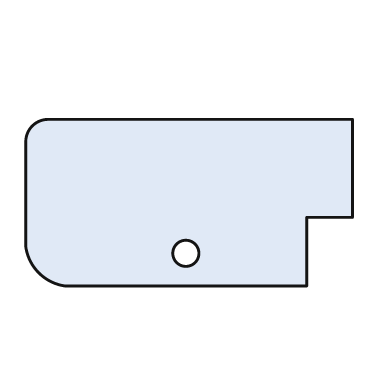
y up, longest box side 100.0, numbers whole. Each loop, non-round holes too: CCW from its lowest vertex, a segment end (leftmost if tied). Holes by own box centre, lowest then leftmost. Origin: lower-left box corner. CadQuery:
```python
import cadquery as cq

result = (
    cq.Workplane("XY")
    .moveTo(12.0, 0.0)
    .lineTo(86.0, 0.0)
    .lineTo(86.0, 21.0)
    .lineTo(100.0, 21.0)
    .lineTo(100.0, 51.0)
    .lineTo(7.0, 51.0)
    .threePointArc((2.0, 49.0), (0.0, 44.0))
    .lineTo(0.0, 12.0)
    .threePointArc((4.0, 4.0), (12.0, 0.0))
    .close()
    .moveTo(49.0, 10.0)
    .circle(4.0)
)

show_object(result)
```